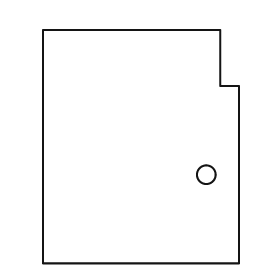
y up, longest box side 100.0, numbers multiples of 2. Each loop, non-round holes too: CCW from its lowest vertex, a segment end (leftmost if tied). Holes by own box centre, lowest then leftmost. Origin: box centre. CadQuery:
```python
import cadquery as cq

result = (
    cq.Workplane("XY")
    .moveTo(-42.0, -50.0)
    .lineTo(42.0, -50.0)
    .lineTo(42.0, 26.0)
    .lineTo(34.0, 26.0)
    .lineTo(34.0, 50.0)
    .lineTo(-42.0, 50.0)
    .close()
    .moveTo(28.0, -12.0)
    .circle(4.0)
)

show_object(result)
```